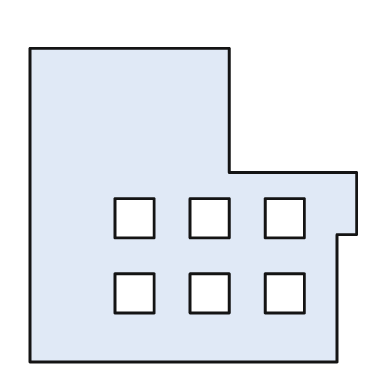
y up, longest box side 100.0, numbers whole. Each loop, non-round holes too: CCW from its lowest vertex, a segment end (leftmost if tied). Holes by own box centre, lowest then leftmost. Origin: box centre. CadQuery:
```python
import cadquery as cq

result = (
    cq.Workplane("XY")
    .moveTo(-50.0, -48.0)
    .lineTo(44.0, -48.0)
    .lineTo(44.0, -9.0)
    .lineTo(50.0, -9.0)
    .lineTo(50.0, 10.0)
    .lineTo(11.0, 10.0)
    .lineTo(11.0, 48.0)
    .lineTo(-50.0, 48.0)
    .close()
    .moveTo(-24.0, -33.0)
    .lineTo(-12.0, -33.0)
    .lineTo(-12.0, -21.0)
    .lineTo(-24.0, -21.0)
    .close()
    .moveTo(-1.0, -33.0)
    .lineTo(11.0, -33.0)
    .lineTo(11.0, -21.0)
    .lineTo(-1.0, -21.0)
    .close()
    .moveTo(22.0, -33.0)
    .lineTo(34.0, -33.0)
    .lineTo(34.0, -21.0)
    .lineTo(22.0, -21.0)
    .close()
    .moveTo(-24.0, -10.0)
    .lineTo(-12.0, -10.0)
    .lineTo(-12.0, 2.0)
    .lineTo(-24.0, 2.0)
    .close()
    .moveTo(-1.0, -10.0)
    .lineTo(11.0, -10.0)
    .lineTo(11.0, 2.0)
    .lineTo(-1.0, 2.0)
    .close()
    .moveTo(22.0, -10.0)
    .lineTo(34.0, -10.0)
    .lineTo(34.0, 2.0)
    .lineTo(22.0, 2.0)
    .close()
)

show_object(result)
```